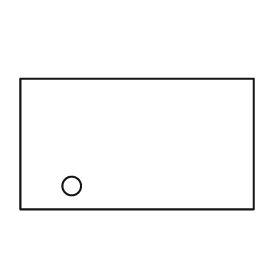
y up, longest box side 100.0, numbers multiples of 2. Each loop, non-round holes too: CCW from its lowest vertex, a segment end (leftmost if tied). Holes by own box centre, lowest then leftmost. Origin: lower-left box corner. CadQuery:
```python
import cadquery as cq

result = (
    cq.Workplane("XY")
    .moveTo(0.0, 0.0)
    .lineTo(100.0, 0.0)
    .lineTo(100.0, 56.0)
    .lineTo(0.0, 56.0)
    .close()
    .moveTo(22.0, 10.0)
    .circle(4.0)
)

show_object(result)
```